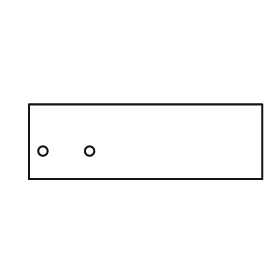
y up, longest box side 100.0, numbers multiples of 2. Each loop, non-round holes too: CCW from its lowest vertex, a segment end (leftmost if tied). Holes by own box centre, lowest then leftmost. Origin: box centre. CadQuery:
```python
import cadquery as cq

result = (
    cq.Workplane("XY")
    .moveTo(-50.0, -16.0)
    .lineTo(50.0, -16.0)
    .lineTo(50.0, 16.0)
    .lineTo(-50.0, 16.0)
    .close()
    .moveTo(-44.0, -4.0)
    .circle(2.0)
    .moveTo(-24.0, -4.0)
    .circle(2.0)
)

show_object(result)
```